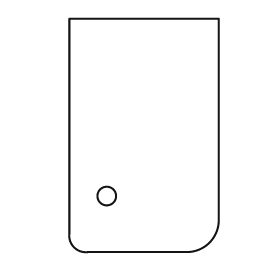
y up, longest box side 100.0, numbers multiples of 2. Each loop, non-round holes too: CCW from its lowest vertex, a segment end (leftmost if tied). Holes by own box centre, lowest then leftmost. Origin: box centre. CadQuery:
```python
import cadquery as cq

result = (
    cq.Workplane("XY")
    .moveTo(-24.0, -50.0)
    .lineTo(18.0, -50.0)
    .threePointArc((28.0, -46.0), (32.0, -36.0))
    .lineTo(32.0, 50.0)
    .lineTo(-32.0, 50.0)
    .lineTo(-32.0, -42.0)
    .threePointArc((-30.0, -48.0), (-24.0, -50.0))
    .close()
    .moveTo(-16.0, -26.0)
    .circle(4.0)
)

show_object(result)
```